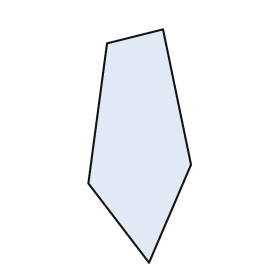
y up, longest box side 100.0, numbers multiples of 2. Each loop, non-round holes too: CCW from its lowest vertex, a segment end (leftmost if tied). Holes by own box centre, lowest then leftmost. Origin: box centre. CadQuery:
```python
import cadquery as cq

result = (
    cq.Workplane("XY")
    .moveTo(4.0, -50.0)
    .lineTo(22.0, -8.0)
    .lineTo(10.0, 50.0)
    .lineTo(-14.0, 44.0)
    .lineTo(-22.0, -16.0)
    .close()
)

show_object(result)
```